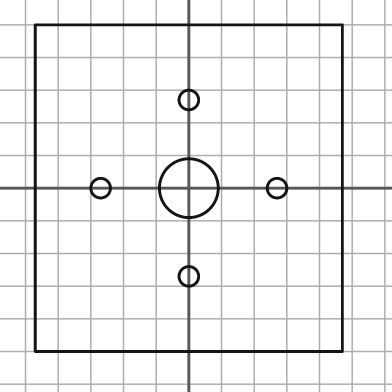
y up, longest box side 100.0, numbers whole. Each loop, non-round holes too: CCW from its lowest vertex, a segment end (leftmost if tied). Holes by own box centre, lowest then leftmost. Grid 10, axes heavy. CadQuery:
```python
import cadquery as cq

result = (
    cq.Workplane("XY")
    .moveTo(-47.0, -50.0)
    .lineTo(47.0, -50.0)
    .lineTo(47.0, 50.0)
    .lineTo(-47.0, 50.0)
    .close()
    .moveTo(0.0, -27.0)
    .circle(3.0)
    .moveTo(-27.0, 0.0)
    .circle(3.0)
    .moveTo(0.0, 0.0)
    .circle(9.0)
    .moveTo(27.0, 0.0)
    .circle(3.0)
    .moveTo(0.0, 27.0)
    .circle(3.0)
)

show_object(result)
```